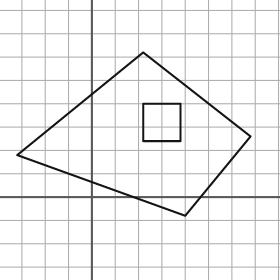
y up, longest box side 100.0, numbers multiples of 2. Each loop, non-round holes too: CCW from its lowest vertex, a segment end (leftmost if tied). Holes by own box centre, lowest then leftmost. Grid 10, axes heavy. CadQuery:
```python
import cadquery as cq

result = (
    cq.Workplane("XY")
    .moveTo(40.0, -8.0)
    .lineTo(68.0, 26.0)
    .lineTo(22.0, 62.0)
    .lineTo(-32.0, 18.0)
    .close()
    .moveTo(22.0, 24.0)
    .lineTo(38.0, 24.0)
    .lineTo(38.0, 40.0)
    .lineTo(22.0, 40.0)
    .close()
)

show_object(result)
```